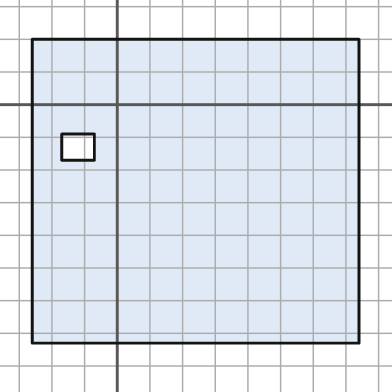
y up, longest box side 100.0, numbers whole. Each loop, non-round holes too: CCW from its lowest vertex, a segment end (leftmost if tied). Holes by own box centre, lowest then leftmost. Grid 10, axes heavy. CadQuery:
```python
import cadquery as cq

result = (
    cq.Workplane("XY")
    .moveTo(-26.0, -73.0)
    .lineTo(74.0, -73.0)
    .lineTo(74.0, 20.0)
    .lineTo(-26.0, 20.0)
    .close()
    .moveTo(-17.0, -17.0)
    .lineTo(-7.0, -17.0)
    .lineTo(-7.0, -9.0)
    .lineTo(-17.0, -9.0)
    .close()
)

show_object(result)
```